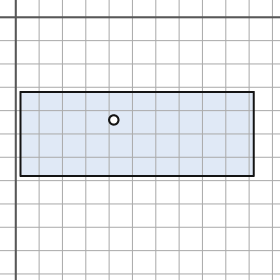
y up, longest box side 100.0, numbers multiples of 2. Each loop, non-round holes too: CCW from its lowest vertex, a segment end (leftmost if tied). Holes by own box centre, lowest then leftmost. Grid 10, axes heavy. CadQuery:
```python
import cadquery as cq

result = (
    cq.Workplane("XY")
    .moveTo(2.0, -68.0)
    .lineTo(102.0, -68.0)
    .lineTo(102.0, -32.0)
    .lineTo(2.0, -32.0)
    .close()
    .moveTo(42.0, -44.0)
    .circle(2.0)
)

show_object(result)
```